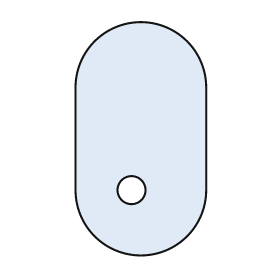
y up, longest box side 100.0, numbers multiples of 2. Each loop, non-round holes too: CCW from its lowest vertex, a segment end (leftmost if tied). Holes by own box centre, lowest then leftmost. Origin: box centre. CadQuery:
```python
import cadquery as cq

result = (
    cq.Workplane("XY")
    .moveTo(-28.0, -22.0)
    .threePointArc((0.0, -50.0), (28.0, -22.0))
    .lineTo(28.0, 22.0)
    .threePointArc((0.0, 50.0), (-28.0, 22.0))
    .close()
    .moveTo(-4.0, -22.0)
    .circle(6.0)
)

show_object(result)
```